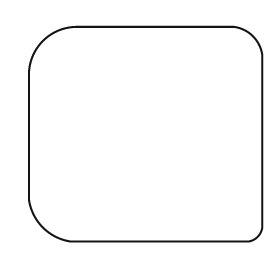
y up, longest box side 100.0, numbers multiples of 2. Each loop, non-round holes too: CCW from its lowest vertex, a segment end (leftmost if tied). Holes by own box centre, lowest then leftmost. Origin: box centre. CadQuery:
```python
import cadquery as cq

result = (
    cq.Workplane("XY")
    .moveTo(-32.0, -46.0)
    .lineTo(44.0, -46.0)
    .threePointArc((48.0, -44.0), (50.0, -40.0))
    .lineTo(50.0, 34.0)
    .threePointArc((46.0, 42.0), (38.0, 46.0))
    .lineTo(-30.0, 46.0)
    .threePointArc((-44.0, 40.0), (-50.0, 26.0))
    .lineTo(-50.0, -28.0)
    .threePointArc((-44.0, -40.0), (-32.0, -46.0))
    .close()
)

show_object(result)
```